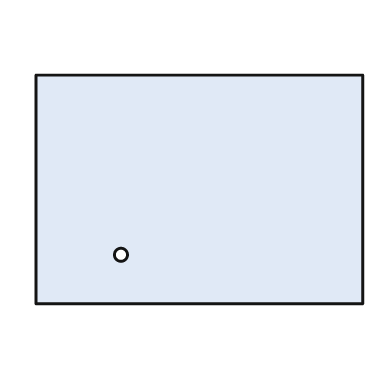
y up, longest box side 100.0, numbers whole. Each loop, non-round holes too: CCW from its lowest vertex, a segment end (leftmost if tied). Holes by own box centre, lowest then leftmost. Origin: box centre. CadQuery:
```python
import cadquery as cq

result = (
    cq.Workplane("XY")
    .moveTo(-50.0, -35.0)
    .lineTo(50.0, -35.0)
    .lineTo(50.0, 35.0)
    .lineTo(-50.0, 35.0)
    .close()
    .moveTo(-24.0, -20.0)
    .circle(2.0)
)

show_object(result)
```